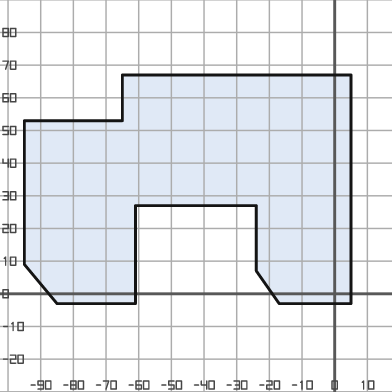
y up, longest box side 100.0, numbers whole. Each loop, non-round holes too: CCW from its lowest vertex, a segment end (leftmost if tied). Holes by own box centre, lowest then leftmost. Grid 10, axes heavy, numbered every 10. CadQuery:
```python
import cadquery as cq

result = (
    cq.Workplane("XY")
    .moveTo(-85.0, -3.0)
    .lineTo(-61.0, -3.0)
    .lineTo(-61.0, 27.0)
    .lineTo(-24.0, 27.0)
    .lineTo(-24.0, 7.0)
    .lineTo(-17.0, -3.0)
    .lineTo(5.0, -3.0)
    .lineTo(5.0, 67.0)
    .lineTo(-65.0, 67.0)
    .lineTo(-65.0, 53.0)
    .lineTo(-95.0, 53.0)
    .lineTo(-95.0, 9.0)
    .close()
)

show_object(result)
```